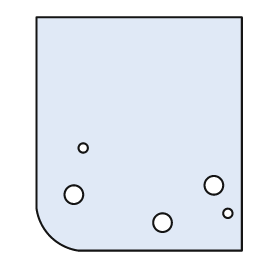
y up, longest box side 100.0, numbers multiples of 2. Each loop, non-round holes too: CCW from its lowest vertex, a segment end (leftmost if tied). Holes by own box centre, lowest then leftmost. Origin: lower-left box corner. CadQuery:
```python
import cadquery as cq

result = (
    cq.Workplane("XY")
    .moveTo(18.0, 0.0)
    .lineTo(88.0, 0.0)
    .lineTo(88.0, 100.0)
    .lineTo(0.0, 100.0)
    .lineTo(0.0, 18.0)
    .threePointArc((6.0, 6.0), (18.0, 0.0))
    .close()
    .moveTo(54.0, 12.0)
    .circle(4.0)
    .moveTo(82.0, 16.0)
    .circle(2.0)
    .moveTo(16.0, 24.0)
    .circle(4.0)
    .moveTo(76.0, 28.0)
    .circle(4.0)
    .moveTo(20.0, 44.0)
    .circle(2.0)
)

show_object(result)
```